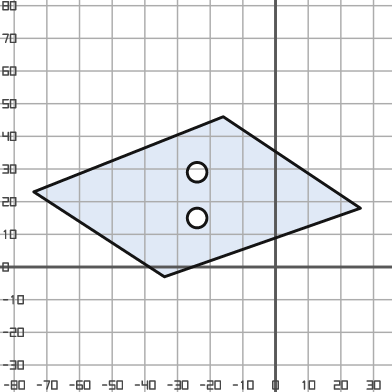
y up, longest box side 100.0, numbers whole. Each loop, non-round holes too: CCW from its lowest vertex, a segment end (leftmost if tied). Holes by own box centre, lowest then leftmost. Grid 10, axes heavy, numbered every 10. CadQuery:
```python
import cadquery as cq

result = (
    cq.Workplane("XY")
    .moveTo(-34.0, -3.0)
    .lineTo(26.0, 18.0)
    .lineTo(-16.0, 46.0)
    .lineTo(-74.0, 23.0)
    .close()
    .moveTo(-24.0, 15.0)
    .circle(3.0)
    .moveTo(-24.0, 29.0)
    .circle(3.0)
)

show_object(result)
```